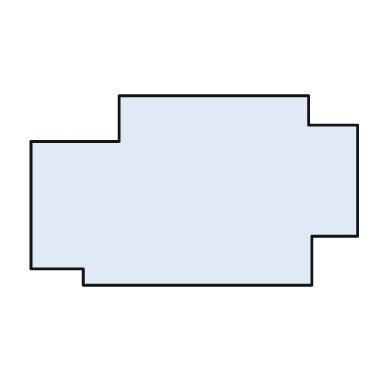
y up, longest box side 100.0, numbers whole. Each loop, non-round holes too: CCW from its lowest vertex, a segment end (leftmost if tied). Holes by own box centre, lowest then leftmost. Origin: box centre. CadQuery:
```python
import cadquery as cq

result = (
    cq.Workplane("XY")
    .moveTo(-34.0, -29.0)
    .lineTo(36.0, -29.0)
    .lineTo(36.0, -14.0)
    .lineTo(50.0, -14.0)
    .lineTo(50.0, 20.0)
    .lineTo(35.0, 20.0)
    .lineTo(35.0, 29.0)
    .lineTo(-23.0, 29.0)
    .lineTo(-23.0, 15.0)
    .lineTo(-50.0, 15.0)
    .lineTo(-50.0, -24.0)
    .lineTo(-34.0, -24.0)
    .close()
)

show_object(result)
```